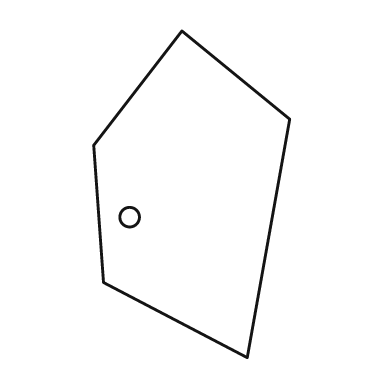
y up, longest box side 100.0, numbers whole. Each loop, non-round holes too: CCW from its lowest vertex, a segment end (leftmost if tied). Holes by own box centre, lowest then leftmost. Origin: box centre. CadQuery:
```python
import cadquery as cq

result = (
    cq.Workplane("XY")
    .moveTo(17.0, -50.0)
    .lineTo(30.0, 23.0)
    .lineTo(-3.0, 50.0)
    .lineTo(-30.0, 15.0)
    .lineTo(-27.0, -27.0)
    .close()
    .moveTo(-19.0, -7.0)
    .circle(3.0)
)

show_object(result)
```